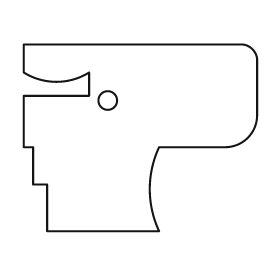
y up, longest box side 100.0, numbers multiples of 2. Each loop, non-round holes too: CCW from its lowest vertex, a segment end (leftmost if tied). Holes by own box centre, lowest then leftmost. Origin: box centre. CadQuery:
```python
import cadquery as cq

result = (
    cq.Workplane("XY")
    .moveTo(-40.0, -40.0)
    .lineTo(8.0, -40.0)
    .threePointArc((4.0, -22.0), (8.0, -4.0))
    .lineTo(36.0, -4.0)
    .threePointArc((46.0, 0.0), (50.0, 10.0))
    .lineTo(50.0, 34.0)
    .threePointArc((48.0, 38.0), (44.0, 40.0))
    .lineTo(-50.0, 40.0)
    .lineTo(-50.0, 28.0)
    .threePointArc((-36.0, 24.0), (-22.0, 28.0))
    .lineTo(-22.0, 18.0)
    .lineTo(-50.0, 18.0)
    .lineTo(-50.0, -4.0)
    .lineTo(-46.0, -4.0)
    .lineTo(-46.0, -20.0)
    .lineTo(-40.0, -20.0)
    .close()
    .moveTo(-14.0, 16.0)
    .circle(4.0)
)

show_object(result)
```